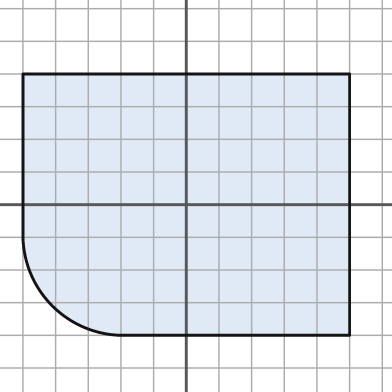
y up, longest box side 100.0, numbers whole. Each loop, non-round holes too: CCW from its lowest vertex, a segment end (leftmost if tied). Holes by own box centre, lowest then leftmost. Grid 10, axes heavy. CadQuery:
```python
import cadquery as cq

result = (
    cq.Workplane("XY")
    .moveTo(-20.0, -40.0)
    .lineTo(50.0, -40.0)
    .lineTo(50.0, 40.0)
    .lineTo(-50.0, 40.0)
    .lineTo(-50.0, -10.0)
    .threePointArc((-41.0, -31.0), (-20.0, -40.0))
    .close()
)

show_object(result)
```